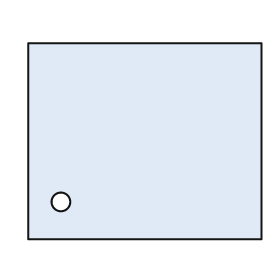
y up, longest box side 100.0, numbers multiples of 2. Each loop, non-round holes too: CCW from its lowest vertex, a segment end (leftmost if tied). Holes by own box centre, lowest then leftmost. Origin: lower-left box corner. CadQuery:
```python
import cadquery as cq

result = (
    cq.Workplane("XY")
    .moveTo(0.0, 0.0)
    .lineTo(100.0, 0.0)
    .lineTo(100.0, 84.0)
    .lineTo(0.0, 84.0)
    .close()
    .moveTo(14.0, 16.0)
    .circle(4.0)
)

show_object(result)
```